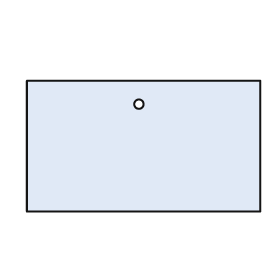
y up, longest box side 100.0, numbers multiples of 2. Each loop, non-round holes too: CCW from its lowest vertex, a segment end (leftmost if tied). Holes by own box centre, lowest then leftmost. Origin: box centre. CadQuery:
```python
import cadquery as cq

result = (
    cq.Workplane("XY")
    .moveTo(-50.0, -28.0)
    .lineTo(50.0, -28.0)
    .lineTo(50.0, 28.0)
    .lineTo(-50.0, 28.0)
    .close()
    .moveTo(-2.0, 18.0)
    .circle(2.0)
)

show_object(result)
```